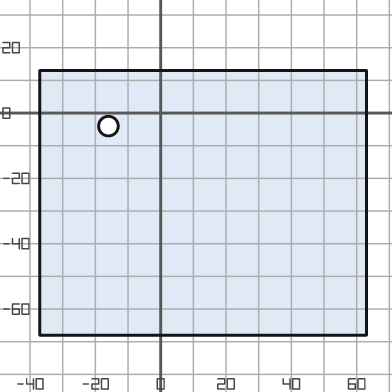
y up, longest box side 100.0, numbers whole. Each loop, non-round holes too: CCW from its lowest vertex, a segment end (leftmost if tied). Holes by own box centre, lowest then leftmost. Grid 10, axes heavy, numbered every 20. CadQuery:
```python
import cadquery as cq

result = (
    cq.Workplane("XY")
    .moveTo(-37.0, -68.0)
    .lineTo(63.0, -68.0)
    .lineTo(63.0, 13.0)
    .lineTo(-37.0, 13.0)
    .close()
    .moveTo(-16.0, -4.0)
    .circle(3.0)
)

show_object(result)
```